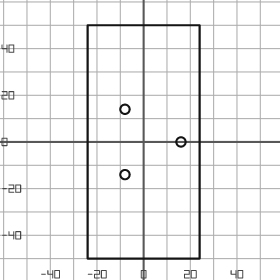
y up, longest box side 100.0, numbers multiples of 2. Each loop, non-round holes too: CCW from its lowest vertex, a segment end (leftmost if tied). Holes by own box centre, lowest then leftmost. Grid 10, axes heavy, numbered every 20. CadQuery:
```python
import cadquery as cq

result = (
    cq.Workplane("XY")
    .moveTo(-24.0, -50.0)
    .lineTo(24.0, -50.0)
    .lineTo(24.0, 50.0)
    .lineTo(-24.0, 50.0)
    .close()
    .moveTo(-8.0, -14.0)
    .circle(2.0)
    .moveTo(16.0, 0.0)
    .circle(2.0)
    .moveTo(-8.0, 14.0)
    .circle(2.0)
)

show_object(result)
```